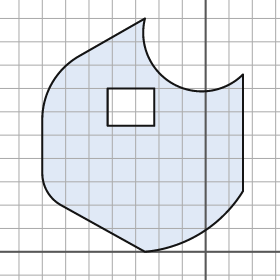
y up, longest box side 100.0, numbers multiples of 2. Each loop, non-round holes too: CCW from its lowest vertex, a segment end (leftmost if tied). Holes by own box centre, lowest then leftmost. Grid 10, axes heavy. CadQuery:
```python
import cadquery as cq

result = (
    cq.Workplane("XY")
    .moveTo(-26.0, 0.0)
    .threePointArc((-2.0, 8.0), (16.0, 26.0))
    .lineTo(16.0, 76.0)
    .threePointArc((-14.0, 72.0), (-26.0, 100.0))
    .lineTo(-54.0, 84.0)
    .threePointArc((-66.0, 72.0), (-70.0, 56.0))
    .lineTo(-70.0, 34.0)
    .threePointArc((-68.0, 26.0), (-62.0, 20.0))
    .close()
    .moveTo(-42.0, 54.0)
    .lineTo(-22.0, 54.0)
    .lineTo(-22.0, 70.0)
    .lineTo(-42.0, 70.0)
    .close()
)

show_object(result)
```